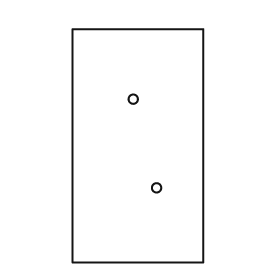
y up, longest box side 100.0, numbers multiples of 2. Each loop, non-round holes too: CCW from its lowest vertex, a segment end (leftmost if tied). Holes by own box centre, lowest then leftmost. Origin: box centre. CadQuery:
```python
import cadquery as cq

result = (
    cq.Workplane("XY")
    .moveTo(-28.0, -50.0)
    .lineTo(28.0, -50.0)
    .lineTo(28.0, 50.0)
    .lineTo(-28.0, 50.0)
    .close()
    .moveTo(8.0, -18.0)
    .circle(2.0)
    .moveTo(-2.0, 20.0)
    .circle(2.0)
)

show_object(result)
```